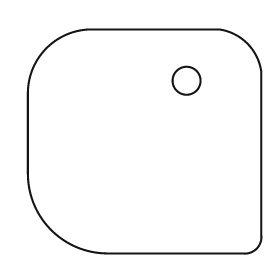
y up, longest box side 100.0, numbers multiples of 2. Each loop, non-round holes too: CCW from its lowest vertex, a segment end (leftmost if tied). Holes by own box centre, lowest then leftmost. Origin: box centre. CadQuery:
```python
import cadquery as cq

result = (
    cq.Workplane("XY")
    .moveTo(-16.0, -48.0)
    .lineTo(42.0, -48.0)
    .threePointArc((48.0, -46.0), (50.0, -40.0))
    .lineTo(50.0, 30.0)
    .threePointArc((44.0, 42.0), (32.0, 48.0))
    .lineTo(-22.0, 48.0)
    .threePointArc((-42.0, 40.0), (-50.0, 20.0))
    .lineTo(-50.0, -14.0)
    .threePointArc((-40.0, -38.0), (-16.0, -48.0))
    .close()
    .moveTo(18.0, 26.0)
    .circle(6.0)
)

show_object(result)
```